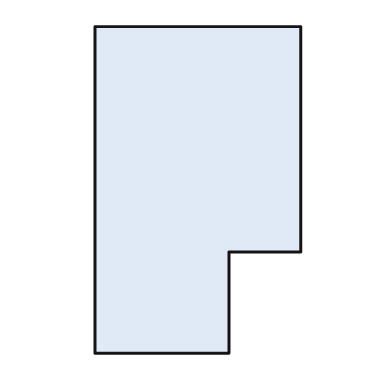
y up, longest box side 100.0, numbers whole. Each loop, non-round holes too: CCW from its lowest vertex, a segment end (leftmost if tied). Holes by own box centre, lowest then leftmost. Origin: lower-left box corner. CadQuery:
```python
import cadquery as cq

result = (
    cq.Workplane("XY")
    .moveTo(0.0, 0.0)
    .lineTo(41.0, 0.0)
    .lineTo(41.0, 31.0)
    .lineTo(63.0, 31.0)
    .lineTo(63.0, 100.0)
    .lineTo(0.0, 100.0)
    .close()
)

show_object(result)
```